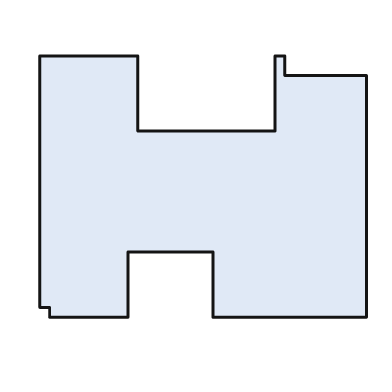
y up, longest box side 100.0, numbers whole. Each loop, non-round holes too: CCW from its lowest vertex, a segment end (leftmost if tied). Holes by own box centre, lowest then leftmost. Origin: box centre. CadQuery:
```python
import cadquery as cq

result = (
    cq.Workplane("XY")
    .moveTo(-47.0, -40.0)
    .lineTo(-23.0, -40.0)
    .lineTo(-23.0, -20.0)
    .lineTo(3.0, -20.0)
    .lineTo(3.0, -40.0)
    .lineTo(50.0, -40.0)
    .lineTo(50.0, 34.0)
    .lineTo(25.0, 34.0)
    .lineTo(25.0, 40.0)
    .lineTo(22.0, 40.0)
    .lineTo(22.0, 17.0)
    .lineTo(-20.0, 17.0)
    .lineTo(-20.0, 40.0)
    .lineTo(-50.0, 40.0)
    .lineTo(-50.0, -37.0)
    .lineTo(-47.0, -37.0)
    .close()
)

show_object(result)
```